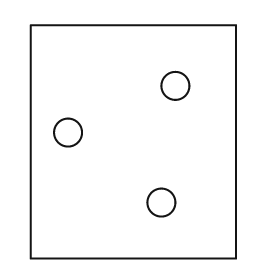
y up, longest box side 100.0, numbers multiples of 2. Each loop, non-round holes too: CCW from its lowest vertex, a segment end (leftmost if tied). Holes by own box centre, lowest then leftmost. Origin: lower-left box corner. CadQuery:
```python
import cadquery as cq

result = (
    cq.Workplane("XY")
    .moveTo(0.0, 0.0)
    .lineTo(88.0, 0.0)
    .lineTo(88.0, 100.0)
    .lineTo(0.0, 100.0)
    .close()
    .moveTo(56.0, 24.0)
    .circle(6.0)
    .moveTo(16.0, 54.0)
    .circle(6.0)
    .moveTo(62.0, 74.0)
    .circle(6.0)
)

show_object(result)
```